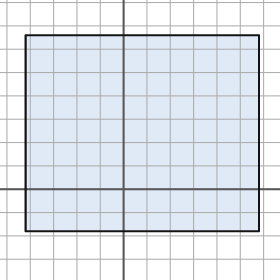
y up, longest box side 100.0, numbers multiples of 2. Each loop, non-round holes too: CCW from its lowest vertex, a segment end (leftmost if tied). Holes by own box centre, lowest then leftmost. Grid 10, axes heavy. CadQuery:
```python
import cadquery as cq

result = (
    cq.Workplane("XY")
    .moveTo(-42.0, -18.0)
    .lineTo(58.0, -18.0)
    .lineTo(58.0, 66.0)
    .lineTo(-42.0, 66.0)
    .close()
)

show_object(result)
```